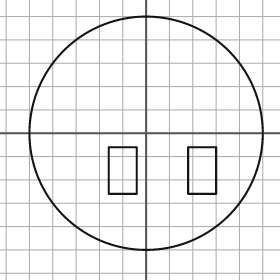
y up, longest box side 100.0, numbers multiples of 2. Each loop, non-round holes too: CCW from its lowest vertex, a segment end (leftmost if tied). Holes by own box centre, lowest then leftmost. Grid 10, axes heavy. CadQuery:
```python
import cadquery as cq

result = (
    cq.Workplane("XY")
    .moveTo(0.0, 0.0)
    .circle(50.0)
    .moveTo(-16.0, -26.0)
    .lineTo(-4.0, -26.0)
    .lineTo(-4.0, -6.0)
    .lineTo(-16.0, -6.0)
    .close()
    .moveTo(18.0, -26.0)
    .lineTo(30.0, -26.0)
    .lineTo(30.0, -6.0)
    .lineTo(18.0, -6.0)
    .close()
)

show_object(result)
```